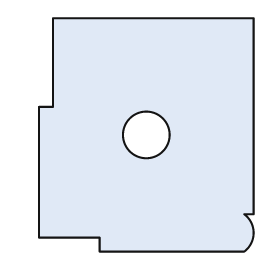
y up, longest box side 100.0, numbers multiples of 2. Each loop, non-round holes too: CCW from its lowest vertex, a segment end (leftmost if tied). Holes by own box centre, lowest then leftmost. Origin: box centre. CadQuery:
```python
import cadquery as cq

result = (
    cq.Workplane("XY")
    .moveTo(-20.0, -50.0)
    .lineTo(42.0, -50.0)
    .threePointArc((46.0, -42.0), (42.0, -34.0))
    .lineTo(46.0, -34.0)
    .lineTo(46.0, 50.0)
    .lineTo(-40.0, 50.0)
    .lineTo(-40.0, 12.0)
    .lineTo(-46.0, 12.0)
    .lineTo(-46.0, -44.0)
    .lineTo(-20.0, -44.0)
    .close()
    .moveTo(0.0, 0.0)
    .circle(10.0)
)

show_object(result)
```